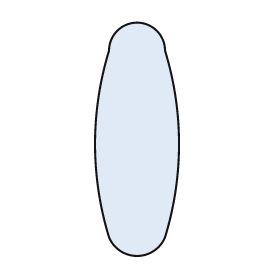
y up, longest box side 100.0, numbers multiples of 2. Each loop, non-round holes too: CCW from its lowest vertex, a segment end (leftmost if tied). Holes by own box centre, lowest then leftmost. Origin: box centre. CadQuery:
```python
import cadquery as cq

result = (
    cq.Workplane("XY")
    .moveTo(-12.0, -42.0)
    .threePointArc((0.0, -50.0), (12.0, -42.0))
    .threePointArc((18.0, -2.0), (12.0, 38.0))
    .threePointArc((0.0, 50.0), (-12.0, 38.0))
    .threePointArc((-18.0, -2.0), (-12.0, -42.0))
    .close()
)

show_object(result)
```